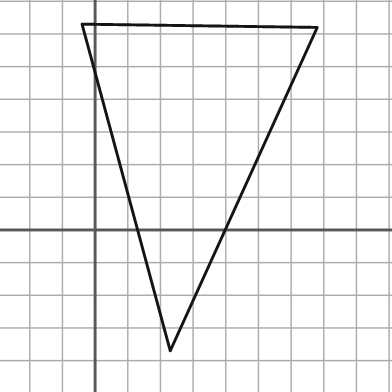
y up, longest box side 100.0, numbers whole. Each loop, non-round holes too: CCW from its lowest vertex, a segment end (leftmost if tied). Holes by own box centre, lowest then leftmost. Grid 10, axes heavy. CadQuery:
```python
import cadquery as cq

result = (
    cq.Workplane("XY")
    .moveTo(23.0, -37.0)
    .lineTo(68.0, 62.0)
    .lineTo(-4.0, 63.0)
    .close()
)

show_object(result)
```